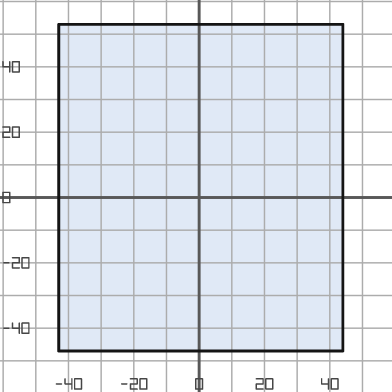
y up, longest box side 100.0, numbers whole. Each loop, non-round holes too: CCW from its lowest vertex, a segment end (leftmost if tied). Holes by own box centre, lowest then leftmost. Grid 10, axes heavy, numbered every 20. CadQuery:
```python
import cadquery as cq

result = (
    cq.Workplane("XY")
    .moveTo(-43.0, -47.0)
    .lineTo(44.0, -47.0)
    .lineTo(44.0, 53.0)
    .lineTo(-43.0, 53.0)
    .close()
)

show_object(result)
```